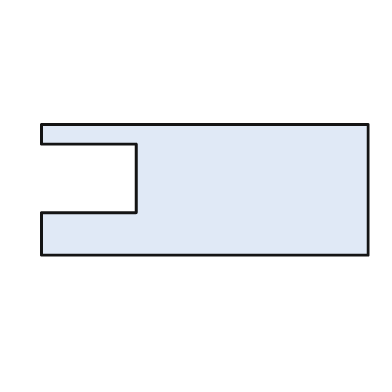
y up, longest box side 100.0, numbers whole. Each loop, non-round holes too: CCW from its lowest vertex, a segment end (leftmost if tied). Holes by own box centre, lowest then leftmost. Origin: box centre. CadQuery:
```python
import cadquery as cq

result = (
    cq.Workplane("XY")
    .moveTo(-50.0, -20.0)
    .lineTo(50.0, -20.0)
    .lineTo(50.0, 20.0)
    .lineTo(-50.0, 20.0)
    .lineTo(-50.0, 14.0)
    .lineTo(-21.0, 14.0)
    .lineTo(-21.0, -7.0)
    .lineTo(-50.0, -7.0)
    .close()
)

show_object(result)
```